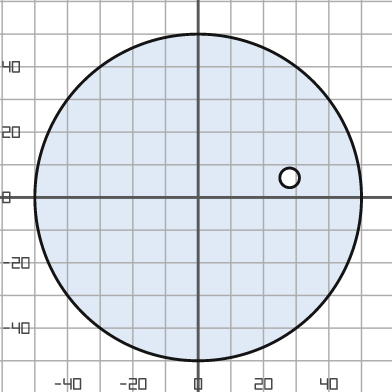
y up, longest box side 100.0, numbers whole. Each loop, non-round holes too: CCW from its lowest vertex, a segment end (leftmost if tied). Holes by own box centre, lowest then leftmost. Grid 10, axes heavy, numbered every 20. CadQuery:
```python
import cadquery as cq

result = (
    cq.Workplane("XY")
    .moveTo(0.0, 0.0)
    .circle(50.0)
    .moveTo(28.0, 6.0)
    .circle(3.0)
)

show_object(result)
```